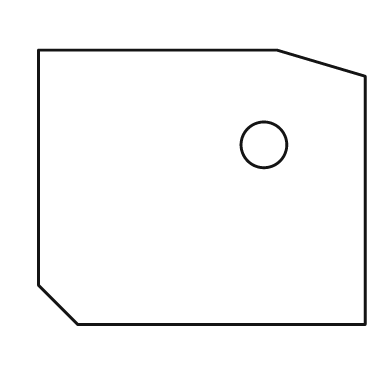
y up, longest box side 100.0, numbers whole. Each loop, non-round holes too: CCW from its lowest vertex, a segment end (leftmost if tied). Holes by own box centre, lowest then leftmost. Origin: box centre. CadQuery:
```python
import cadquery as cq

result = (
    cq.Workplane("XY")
    .moveTo(-38.0, -42.0)
    .lineTo(50.0, -42.0)
    .lineTo(50.0, 34.0)
    .lineTo(23.0, 42.0)
    .lineTo(-50.0, 42.0)
    .lineTo(-50.0, -30.0)
    .close()
    .moveTo(19.0, 13.0)
    .circle(7.0)
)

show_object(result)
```